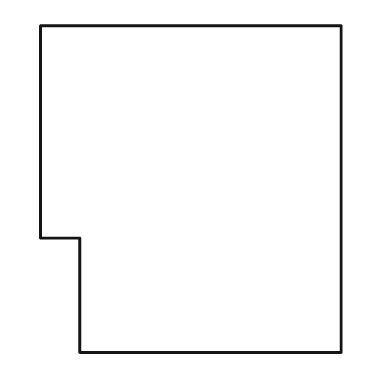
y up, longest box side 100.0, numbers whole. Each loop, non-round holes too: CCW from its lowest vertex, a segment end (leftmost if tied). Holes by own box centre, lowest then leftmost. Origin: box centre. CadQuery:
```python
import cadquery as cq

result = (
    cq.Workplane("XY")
    .moveTo(-34.0, -50.0)
    .lineTo(46.0, -50.0)
    .lineTo(46.0, 50.0)
    .lineTo(-46.0, 50.0)
    .lineTo(-46.0, -15.0)
    .lineTo(-34.0, -15.0)
    .close()
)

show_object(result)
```